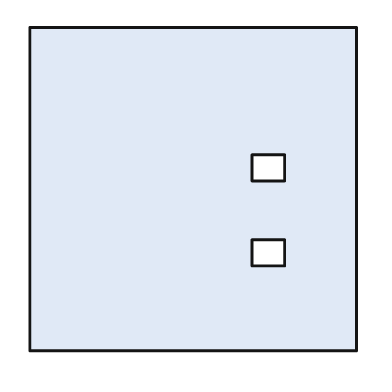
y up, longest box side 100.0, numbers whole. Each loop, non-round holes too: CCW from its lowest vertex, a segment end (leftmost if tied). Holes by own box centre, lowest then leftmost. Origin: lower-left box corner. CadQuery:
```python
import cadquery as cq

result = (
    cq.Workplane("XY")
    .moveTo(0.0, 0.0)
    .lineTo(100.0, 0.0)
    .lineTo(100.0, 99.0)
    .lineTo(0.0, 99.0)
    .close()
    .moveTo(68.0, 26.0)
    .lineTo(78.0, 26.0)
    .lineTo(78.0, 34.0)
    .lineTo(68.0, 34.0)
    .close()
    .moveTo(68.0, 52.0)
    .lineTo(78.0, 52.0)
    .lineTo(78.0, 60.0)
    .lineTo(68.0, 60.0)
    .close()
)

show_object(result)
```